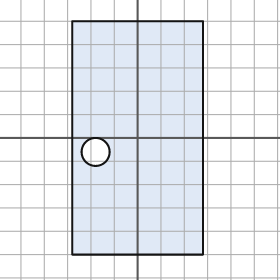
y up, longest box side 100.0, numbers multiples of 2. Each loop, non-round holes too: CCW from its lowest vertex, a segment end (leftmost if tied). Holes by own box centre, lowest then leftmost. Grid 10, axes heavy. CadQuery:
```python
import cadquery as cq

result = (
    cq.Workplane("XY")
    .moveTo(-28.0, -50.0)
    .lineTo(28.0, -50.0)
    .lineTo(28.0, 50.0)
    .lineTo(-28.0, 50.0)
    .close()
    .moveTo(-18.0, -6.0)
    .circle(6.0)
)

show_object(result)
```